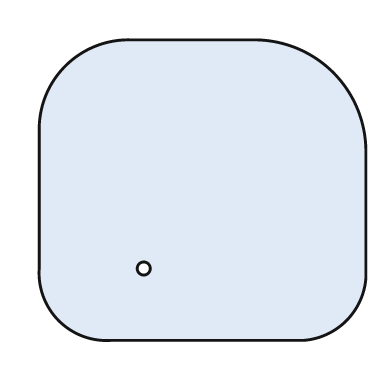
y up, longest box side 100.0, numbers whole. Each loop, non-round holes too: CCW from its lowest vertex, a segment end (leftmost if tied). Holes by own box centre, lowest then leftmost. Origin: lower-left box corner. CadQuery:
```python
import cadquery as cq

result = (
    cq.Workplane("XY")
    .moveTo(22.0, 0.0)
    .lineTo(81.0, 0.0)
    .threePointArc((94.0, 6.0), (100.0, 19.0))
    .lineTo(100.0, 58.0)
    .threePointArc((90.0, 82.0), (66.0, 92.0))
    .lineTo(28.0, 92.0)
    .threePointArc((8.0, 84.0), (0.0, 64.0))
    .lineTo(0.0, 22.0)
    .threePointArc((6.0, 6.0), (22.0, 0.0))
    .close()
    .moveTo(32.0, 22.0)
    .circle(2.0)
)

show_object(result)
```